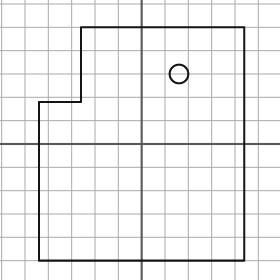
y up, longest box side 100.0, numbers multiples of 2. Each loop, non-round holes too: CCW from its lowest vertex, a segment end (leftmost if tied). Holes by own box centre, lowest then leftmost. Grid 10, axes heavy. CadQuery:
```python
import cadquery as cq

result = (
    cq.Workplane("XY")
    .moveTo(-44.0, -50.0)
    .lineTo(44.0, -50.0)
    .lineTo(44.0, 50.0)
    .lineTo(-26.0, 50.0)
    .lineTo(-26.0, 18.0)
    .lineTo(-44.0, 18.0)
    .close()
    .moveTo(16.0, 30.0)
    .circle(4.0)
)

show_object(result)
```